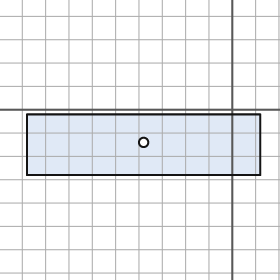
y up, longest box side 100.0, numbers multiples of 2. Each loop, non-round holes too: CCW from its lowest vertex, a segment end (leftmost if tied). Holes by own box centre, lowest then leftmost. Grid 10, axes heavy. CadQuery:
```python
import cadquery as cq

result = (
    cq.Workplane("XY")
    .moveTo(-88.0, -28.0)
    .lineTo(12.0, -28.0)
    .lineTo(12.0, -2.0)
    .lineTo(-88.0, -2.0)
    .close()
    .moveTo(-38.0, -14.0)
    .circle(2.0)
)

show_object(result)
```